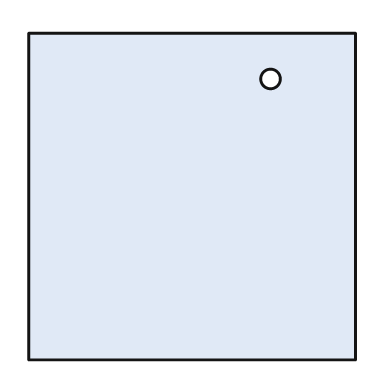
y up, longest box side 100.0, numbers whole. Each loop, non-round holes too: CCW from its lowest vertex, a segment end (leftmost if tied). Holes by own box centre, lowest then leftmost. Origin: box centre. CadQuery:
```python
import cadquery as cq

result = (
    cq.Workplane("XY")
    .moveTo(-50.0, -50.0)
    .lineTo(50.0, -50.0)
    .lineTo(50.0, 50.0)
    .lineTo(-50.0, 50.0)
    .close()
    .moveTo(24.0, 36.0)
    .circle(3.0)
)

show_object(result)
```